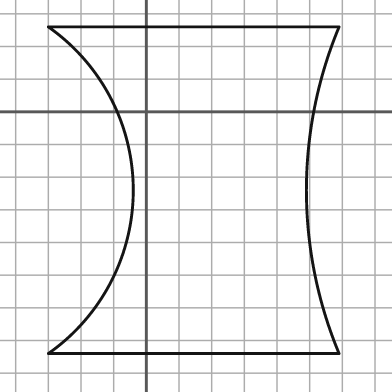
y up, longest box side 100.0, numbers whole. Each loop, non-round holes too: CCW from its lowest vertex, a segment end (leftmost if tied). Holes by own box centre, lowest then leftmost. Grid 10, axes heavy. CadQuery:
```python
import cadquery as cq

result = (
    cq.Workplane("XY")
    .moveTo(-30.0, -74.0)
    .lineTo(59.0, -74.0)
    .threePointArc((49.0, -24.0), (59.0, 26.0))
    .lineTo(-30.0, 26.0)
    .threePointArc((-4.0, -24.0), (-30.0, -74.0))
    .close()
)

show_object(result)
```